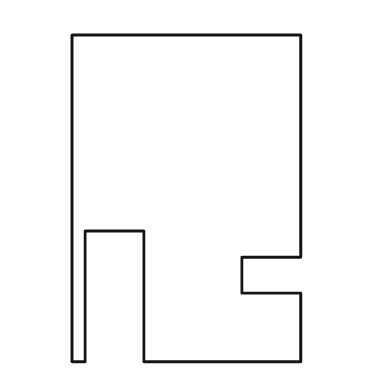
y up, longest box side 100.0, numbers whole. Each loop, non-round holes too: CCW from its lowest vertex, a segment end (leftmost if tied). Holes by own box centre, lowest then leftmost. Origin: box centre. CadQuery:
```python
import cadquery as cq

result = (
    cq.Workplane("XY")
    .moveTo(-35.0, -50.0)
    .lineTo(-31.0, -50.0)
    .lineTo(-31.0, -10.0)
    .lineTo(-13.0, -10.0)
    .lineTo(-13.0, -50.0)
    .lineTo(35.0, -50.0)
    .lineTo(35.0, -29.0)
    .lineTo(17.0, -29.0)
    .lineTo(17.0, -18.0)
    .lineTo(35.0, -18.0)
    .lineTo(35.0, 50.0)
    .lineTo(-35.0, 50.0)
    .close()
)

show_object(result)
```